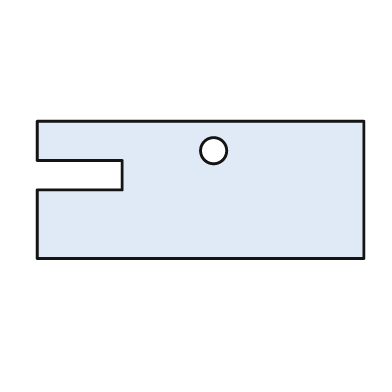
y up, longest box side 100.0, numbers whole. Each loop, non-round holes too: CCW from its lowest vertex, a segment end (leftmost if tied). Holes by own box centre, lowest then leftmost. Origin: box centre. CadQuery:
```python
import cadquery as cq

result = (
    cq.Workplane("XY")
    .moveTo(-50.0, -21.0)
    .lineTo(50.0, -21.0)
    .lineTo(50.0, 21.0)
    .lineTo(-50.0, 21.0)
    .lineTo(-50.0, 9.0)
    .lineTo(-24.0, 9.0)
    .lineTo(-24.0, 0.0)
    .lineTo(-50.0, 0.0)
    .close()
    .moveTo(4.0, 12.0)
    .circle(4.0)
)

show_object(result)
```